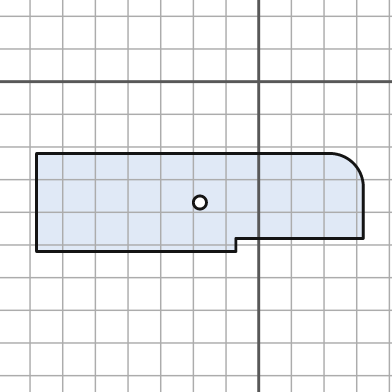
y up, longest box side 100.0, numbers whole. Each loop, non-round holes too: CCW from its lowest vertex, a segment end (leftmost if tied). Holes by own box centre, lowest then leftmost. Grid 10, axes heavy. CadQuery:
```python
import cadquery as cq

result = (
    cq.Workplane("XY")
    .moveTo(-68.0, -52.0)
    .lineTo(-7.0, -52.0)
    .lineTo(-7.0, -48.0)
    .lineTo(32.0, -48.0)
    .lineTo(32.0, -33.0)
    .threePointArc((29.0, -25.0), (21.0, -22.0))
    .lineTo(-68.0, -22.0)
    .close()
    .moveTo(-18.0, -37.0)
    .circle(2.0)
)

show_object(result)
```